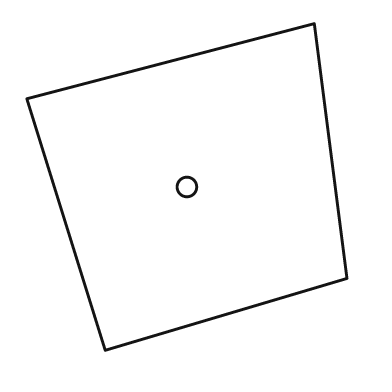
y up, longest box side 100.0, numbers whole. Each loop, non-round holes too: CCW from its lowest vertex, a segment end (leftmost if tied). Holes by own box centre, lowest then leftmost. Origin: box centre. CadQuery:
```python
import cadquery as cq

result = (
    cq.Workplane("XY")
    .moveTo(-25.0, -50.0)
    .lineTo(49.0, -28.0)
    .lineTo(39.0, 50.0)
    .lineTo(-49.0, 27.0)
    .close()
    .moveTo(0.0, 0.0)
    .circle(3.0)
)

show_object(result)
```